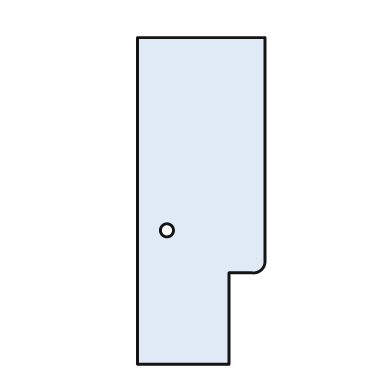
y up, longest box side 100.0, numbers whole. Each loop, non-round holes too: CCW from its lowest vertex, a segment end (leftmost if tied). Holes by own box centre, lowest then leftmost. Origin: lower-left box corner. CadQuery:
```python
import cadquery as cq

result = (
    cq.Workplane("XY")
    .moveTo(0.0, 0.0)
    .lineTo(28.0, 0.0)
    .lineTo(28.0, 28.0)
    .lineTo(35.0, 28.0)
    .threePointArc((38.0, 29.0), (39.0, 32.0))
    .lineTo(39.0, 100.0)
    .lineTo(0.0, 100.0)
    .close()
    .moveTo(9.0, 41.0)
    .circle(2.0)
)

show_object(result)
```